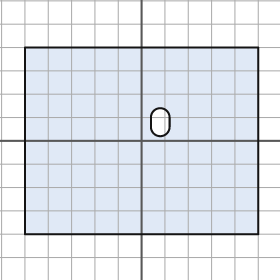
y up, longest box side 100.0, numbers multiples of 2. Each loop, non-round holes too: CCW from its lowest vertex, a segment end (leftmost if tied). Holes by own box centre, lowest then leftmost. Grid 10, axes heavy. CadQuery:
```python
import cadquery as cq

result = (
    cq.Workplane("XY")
    .moveTo(-50.0, -40.0)
    .lineTo(50.0, -40.0)
    .lineTo(50.0, 40.0)
    .lineTo(-50.0, 40.0)
    .close()
    .moveTo(4.0, 6.0)
    .threePointArc((8.0, 2.0), (12.0, 6.0))
    .lineTo(12.0, 10.0)
    .threePointArc((8.0, 14.0), (4.0, 10.0))
    .close()
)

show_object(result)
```